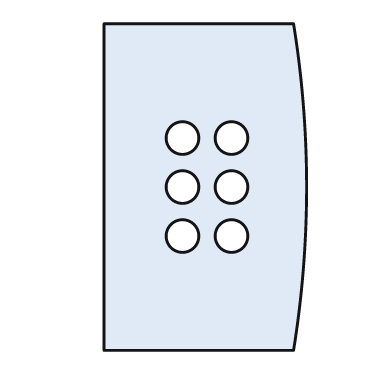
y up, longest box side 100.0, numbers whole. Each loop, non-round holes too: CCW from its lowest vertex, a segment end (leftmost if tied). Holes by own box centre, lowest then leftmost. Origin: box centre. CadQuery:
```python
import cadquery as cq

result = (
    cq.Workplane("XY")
    .moveTo(-31.0, -50.0)
    .lineTo(27.0, -50.0)
    .threePointArc((31.0, 0.0), (27.0, 50.0))
    .lineTo(-31.0, 50.0)
    .close()
    .moveTo(-7.0, -15.0)
    .circle(5.0)
    .moveTo(8.0, -15.0)
    .circle(5.0)
    .moveTo(-7.0, 0.0)
    .circle(5.0)
    .moveTo(8.0, 0.0)
    .circle(5.0)
    .moveTo(-7.0, 15.0)
    .circle(5.0)
    .moveTo(8.0, 15.0)
    .circle(5.0)
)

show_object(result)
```